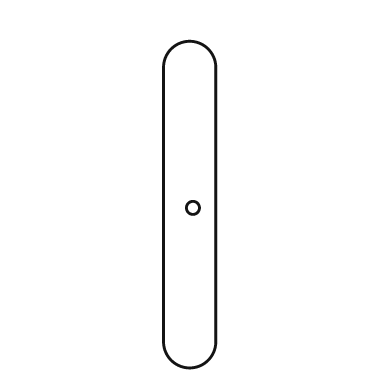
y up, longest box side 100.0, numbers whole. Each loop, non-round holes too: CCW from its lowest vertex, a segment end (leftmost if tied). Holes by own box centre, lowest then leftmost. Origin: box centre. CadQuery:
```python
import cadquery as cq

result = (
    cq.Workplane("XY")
    .moveTo(-8.0, -42.0)
    .threePointArc((0.0, -50.0), (8.0, -42.0))
    .lineTo(8.0, 42.0)
    .threePointArc((0.0, 50.0), (-8.0, 42.0))
    .close()
    .moveTo(1.0, -1.0)
    .circle(2.0)
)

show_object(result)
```